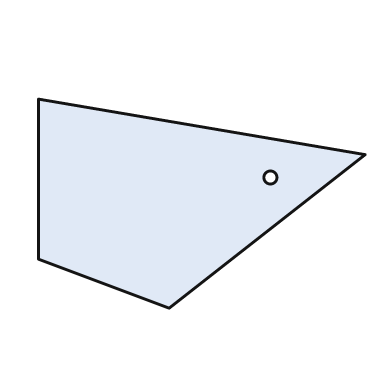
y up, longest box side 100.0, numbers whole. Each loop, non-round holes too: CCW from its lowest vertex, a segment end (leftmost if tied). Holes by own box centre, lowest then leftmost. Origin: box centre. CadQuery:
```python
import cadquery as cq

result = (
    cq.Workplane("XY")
    .moveTo(-10.0, -32.0)
    .lineTo(50.0, 15.0)
    .lineTo(-50.0, 32.0)
    .lineTo(-50.0, -17.0)
    .close()
    .moveTo(21.0, 8.0)
    .circle(2.0)
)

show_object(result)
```